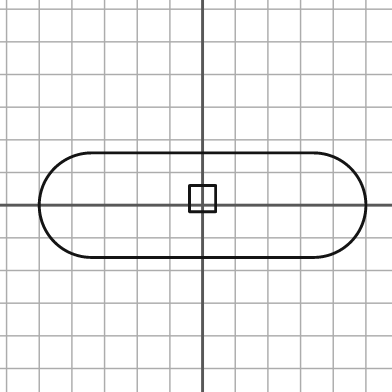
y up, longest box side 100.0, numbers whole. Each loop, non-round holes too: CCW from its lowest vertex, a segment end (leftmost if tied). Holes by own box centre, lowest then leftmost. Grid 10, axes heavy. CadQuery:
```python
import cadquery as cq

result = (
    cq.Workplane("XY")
    .moveTo(-34.0, -16.0)
    .lineTo(34.0, -16.0)
    .threePointArc((50.0, 0.0), (34.0, 16.0))
    .lineTo(-34.0, 16.0)
    .threePointArc((-50.0, 0.0), (-34.0, -16.0))
    .close()
    .moveTo(-4.0, -2.0)
    .lineTo(4.0, -2.0)
    .lineTo(4.0, 6.0)
    .lineTo(-4.0, 6.0)
    .close()
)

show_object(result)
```